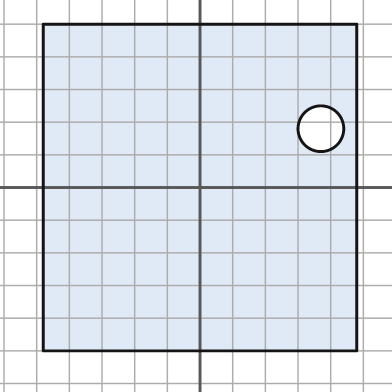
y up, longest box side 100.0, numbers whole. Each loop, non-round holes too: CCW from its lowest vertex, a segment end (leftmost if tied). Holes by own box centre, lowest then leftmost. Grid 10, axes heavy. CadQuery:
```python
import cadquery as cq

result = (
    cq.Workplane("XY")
    .moveTo(-48.0, -50.0)
    .lineTo(48.0, -50.0)
    .lineTo(48.0, 50.0)
    .lineTo(-48.0, 50.0)
    .close()
    .moveTo(37.0, 18.0)
    .circle(7.0)
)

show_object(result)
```